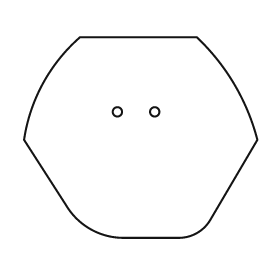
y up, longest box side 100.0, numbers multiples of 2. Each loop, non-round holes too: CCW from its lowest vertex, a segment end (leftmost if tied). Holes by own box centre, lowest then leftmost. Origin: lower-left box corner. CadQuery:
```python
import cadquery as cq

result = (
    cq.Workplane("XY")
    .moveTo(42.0, 0.0)
    .lineTo(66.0, 0.0)
    .threePointArc((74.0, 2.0), (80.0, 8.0))
    .lineTo(100.0, 42.0)
    .threePointArc((90.0, 66.0), (74.0, 86.0))
    .lineTo(24.0, 86.0)
    .threePointArc((8.0, 66.0), (0.0, 42.0))
    .lineTo(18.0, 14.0)
    .threePointArc((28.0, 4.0), (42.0, 0.0))
    .close()
    .moveTo(40.0, 54.0)
    .circle(2.0)
    .moveTo(56.0, 54.0)
    .circle(2.0)
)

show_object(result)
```